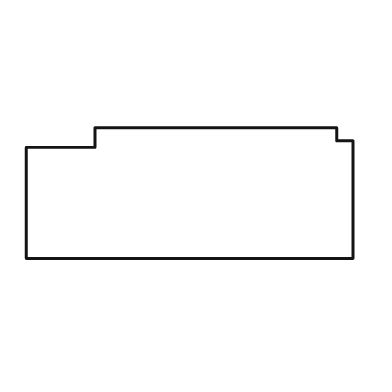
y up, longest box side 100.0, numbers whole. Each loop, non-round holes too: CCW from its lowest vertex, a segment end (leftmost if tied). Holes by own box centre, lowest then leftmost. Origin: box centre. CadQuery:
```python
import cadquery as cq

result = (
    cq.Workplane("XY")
    .moveTo(-50.0, -20.0)
    .lineTo(50.0, -20.0)
    .lineTo(50.0, 16.0)
    .lineTo(45.0, 16.0)
    .lineTo(45.0, 20.0)
    .lineTo(-29.0, 20.0)
    .lineTo(-29.0, 14.0)
    .lineTo(-50.0, 14.0)
    .close()
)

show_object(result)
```